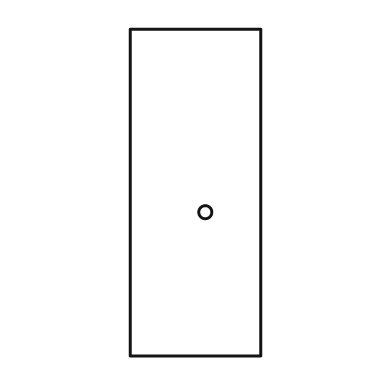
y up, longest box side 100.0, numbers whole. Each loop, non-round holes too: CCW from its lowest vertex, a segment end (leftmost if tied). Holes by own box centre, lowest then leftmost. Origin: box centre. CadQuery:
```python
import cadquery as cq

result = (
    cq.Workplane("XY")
    .moveTo(-20.0, -50.0)
    .lineTo(20.0, -50.0)
    .lineTo(20.0, 50.0)
    .lineTo(-20.0, 50.0)
    .close()
    .moveTo(3.0, -6.0)
    .circle(2.0)
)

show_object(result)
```